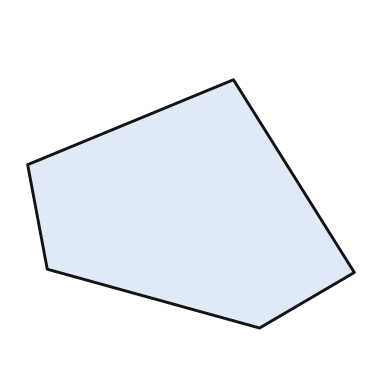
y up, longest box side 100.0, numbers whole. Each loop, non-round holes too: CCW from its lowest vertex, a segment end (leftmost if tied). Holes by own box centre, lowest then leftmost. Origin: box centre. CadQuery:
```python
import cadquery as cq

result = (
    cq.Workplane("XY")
    .moveTo(21.0, -38.0)
    .lineTo(50.0, -21.0)
    .lineTo(13.0, 38.0)
    .lineTo(-50.0, 12.0)
    .lineTo(-44.0, -20.0)
    .close()
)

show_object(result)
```